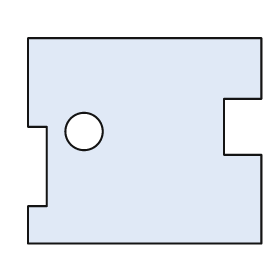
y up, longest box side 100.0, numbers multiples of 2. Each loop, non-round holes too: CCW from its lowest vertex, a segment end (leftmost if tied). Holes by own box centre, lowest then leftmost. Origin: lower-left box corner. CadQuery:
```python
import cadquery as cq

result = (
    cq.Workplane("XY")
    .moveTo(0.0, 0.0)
    .lineTo(100.0, 0.0)
    .lineTo(100.0, 38.0)
    .lineTo(84.0, 38.0)
    .lineTo(84.0, 62.0)
    .lineTo(100.0, 62.0)
    .lineTo(100.0, 88.0)
    .lineTo(0.0, 88.0)
    .lineTo(0.0, 50.0)
    .lineTo(8.0, 50.0)
    .lineTo(8.0, 16.0)
    .lineTo(0.0, 16.0)
    .close()
    .moveTo(24.0, 48.0)
    .circle(8.0)
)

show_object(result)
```